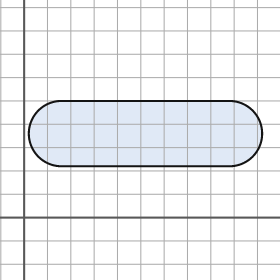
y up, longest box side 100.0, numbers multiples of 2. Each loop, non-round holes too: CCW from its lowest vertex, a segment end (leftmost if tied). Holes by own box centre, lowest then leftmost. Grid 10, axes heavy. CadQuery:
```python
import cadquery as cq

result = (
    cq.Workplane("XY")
    .moveTo(16.0, 22.0)
    .lineTo(88.0, 22.0)
    .threePointArc((102.0, 36.0), (88.0, 50.0))
    .lineTo(16.0, 50.0)
    .threePointArc((2.0, 36.0), (16.0, 22.0))
    .close()
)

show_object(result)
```